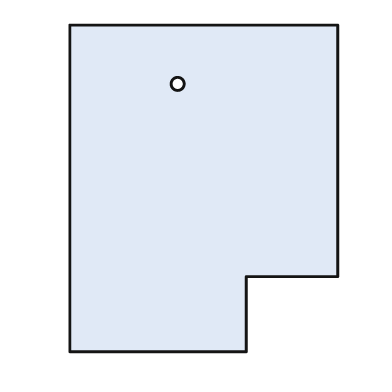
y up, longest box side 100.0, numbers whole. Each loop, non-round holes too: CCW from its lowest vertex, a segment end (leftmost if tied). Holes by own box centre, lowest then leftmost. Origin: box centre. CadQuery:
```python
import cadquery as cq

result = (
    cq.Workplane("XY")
    .moveTo(-41.0, -50.0)
    .lineTo(13.0, -50.0)
    .lineTo(13.0, -27.0)
    .lineTo(41.0, -27.0)
    .lineTo(41.0, 50.0)
    .lineTo(-41.0, 50.0)
    .close()
    .moveTo(-8.0, 32.0)
    .circle(2.0)
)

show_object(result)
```